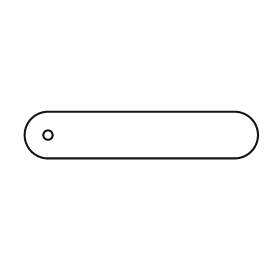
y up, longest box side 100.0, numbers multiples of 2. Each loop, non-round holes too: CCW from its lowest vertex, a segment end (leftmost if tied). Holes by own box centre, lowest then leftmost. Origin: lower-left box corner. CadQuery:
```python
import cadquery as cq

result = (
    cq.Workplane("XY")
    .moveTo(10.0, 0.0)
    .lineTo(90.0, 0.0)
    .threePointArc((100.0, 10.0), (90.0, 20.0))
    .lineTo(10.0, 20.0)
    .threePointArc((0.0, 10.0), (10.0, 0.0))
    .close()
    .moveTo(10.0, 10.0)
    .circle(2.0)
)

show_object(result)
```